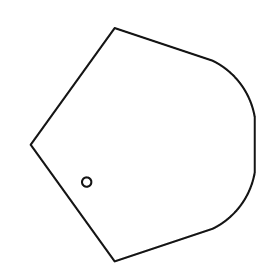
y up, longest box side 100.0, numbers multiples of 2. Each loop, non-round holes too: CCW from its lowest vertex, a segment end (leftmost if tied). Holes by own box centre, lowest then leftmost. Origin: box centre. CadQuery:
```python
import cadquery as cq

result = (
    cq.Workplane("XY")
    .moveTo(-12.0, -50.0)
    .lineTo(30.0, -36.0)
    .threePointArc((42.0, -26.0), (48.0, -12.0))
    .lineTo(48.0, 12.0)
    .threePointArc((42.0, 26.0), (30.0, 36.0))
    .lineTo(-12.0, 50.0)
    .lineTo(-48.0, 0.0)
    .close()
    .moveTo(-24.0, -16.0)
    .circle(2.0)
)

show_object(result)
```